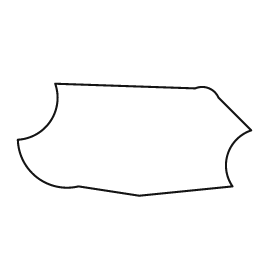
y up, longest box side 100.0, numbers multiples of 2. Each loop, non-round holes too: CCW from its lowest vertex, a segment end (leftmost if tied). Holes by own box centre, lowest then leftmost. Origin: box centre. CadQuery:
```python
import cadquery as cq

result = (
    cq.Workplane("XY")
    .moveTo(2.0, -24.0)
    .lineTo(42.0, -20.0)
    .threePointArc((40.0, -6.0), (50.0, 4.0))
    .lineTo(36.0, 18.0)
    .threePointArc((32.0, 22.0), (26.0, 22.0))
    .lineTo(-34.0, 24.0)
    .threePointArc((-36.0, 8.0), (-50.0, 0.0))
    .threePointArc((-42.0, -16.0), (-24.0, -20.0))
    .close()
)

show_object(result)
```